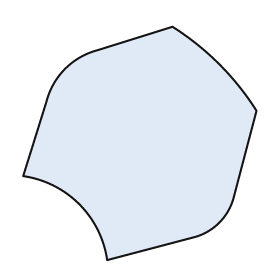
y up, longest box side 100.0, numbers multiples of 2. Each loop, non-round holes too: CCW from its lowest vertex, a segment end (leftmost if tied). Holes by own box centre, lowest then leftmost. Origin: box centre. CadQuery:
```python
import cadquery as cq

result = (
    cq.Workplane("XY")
    .moveTo(-14.0, -50.0)
    .lineTo(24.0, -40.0)
    .threePointArc((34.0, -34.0), (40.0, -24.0))
    .lineTo(50.0, 14.0)
    .threePointArc((34.0, 34.0), (14.0, 50.0))
    .lineTo(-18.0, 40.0)
    .threePointArc((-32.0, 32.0), (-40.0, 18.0))
    .lineTo(-50.0, -14.0)
    .threePointArc((-26.0, -26.0), (-14.0, -50.0))
    .close()
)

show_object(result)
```